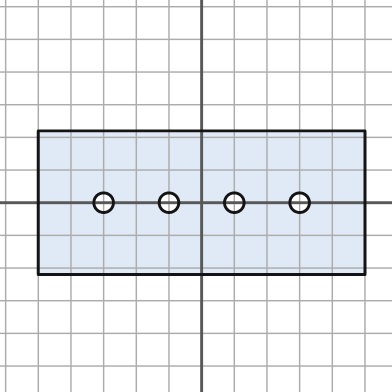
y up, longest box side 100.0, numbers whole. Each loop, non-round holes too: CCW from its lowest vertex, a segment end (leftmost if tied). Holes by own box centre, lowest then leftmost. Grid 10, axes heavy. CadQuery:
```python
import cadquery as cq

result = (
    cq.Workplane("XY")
    .moveTo(-50.0, -22.0)
    .lineTo(50.0, -22.0)
    .lineTo(50.0, 22.0)
    .lineTo(-50.0, 22.0)
    .close()
    .moveTo(-30.0, 0.0)
    .circle(3.0)
    .moveTo(-10.0, 0.0)
    .circle(3.0)
    .moveTo(10.0, 0.0)
    .circle(3.0)
    .moveTo(30.0, 0.0)
    .circle(3.0)
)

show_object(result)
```